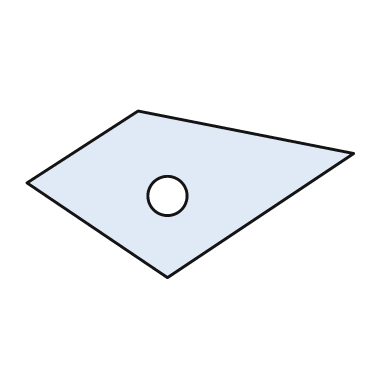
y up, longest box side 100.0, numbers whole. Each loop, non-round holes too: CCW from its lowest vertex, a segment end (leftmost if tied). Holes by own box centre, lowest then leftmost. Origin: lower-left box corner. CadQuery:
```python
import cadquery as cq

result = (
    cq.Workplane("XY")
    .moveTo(43.0, 0.0)
    .lineTo(100.0, 38.0)
    .lineTo(34.0, 51.0)
    .lineTo(0.0, 29.0)
    .close()
    .moveTo(43.0, 25.0)
    .circle(6.0)
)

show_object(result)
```